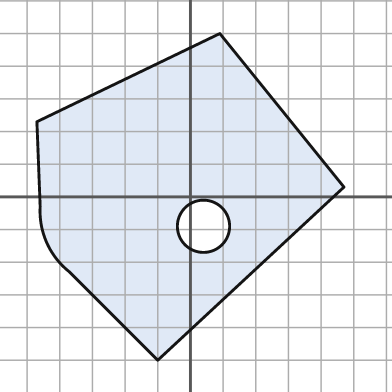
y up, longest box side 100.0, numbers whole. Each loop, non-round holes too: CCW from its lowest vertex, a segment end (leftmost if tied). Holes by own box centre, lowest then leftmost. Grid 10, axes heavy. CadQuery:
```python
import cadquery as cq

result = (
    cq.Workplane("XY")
    .moveTo(-10.0, -50.0)
    .lineTo(47.0, 3.0)
    .lineTo(9.0, 50.0)
    .lineTo(-47.0, 23.0)
    .lineTo(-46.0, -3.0)
    .threePointArc((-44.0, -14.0), (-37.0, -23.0))
    .close()
    .moveTo(4.0, -9.0)
    .circle(8.0)
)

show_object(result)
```